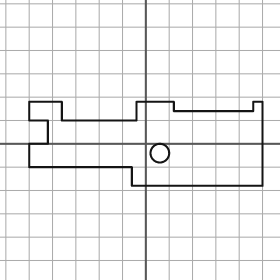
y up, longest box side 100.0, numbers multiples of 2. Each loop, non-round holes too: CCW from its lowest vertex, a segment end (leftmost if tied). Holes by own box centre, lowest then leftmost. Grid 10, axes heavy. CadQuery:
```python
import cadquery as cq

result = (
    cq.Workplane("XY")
    .moveTo(-6.0, -18.0)
    .lineTo(50.0, -18.0)
    .lineTo(50.0, 18.0)
    .lineTo(46.0, 18.0)
    .lineTo(46.0, 14.0)
    .lineTo(12.0, 14.0)
    .lineTo(12.0, 18.0)
    .lineTo(-4.0, 18.0)
    .lineTo(-4.0, 10.0)
    .lineTo(-36.0, 10.0)
    .lineTo(-36.0, 18.0)
    .lineTo(-50.0, 18.0)
    .lineTo(-50.0, 10.0)
    .lineTo(-42.0, 10.0)
    .lineTo(-42.0, 0.0)
    .lineTo(-50.0, 0.0)
    .lineTo(-50.0, -10.0)
    .lineTo(-6.0, -10.0)
    .close()
    .moveTo(6.0, -4.0)
    .circle(4.0)
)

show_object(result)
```